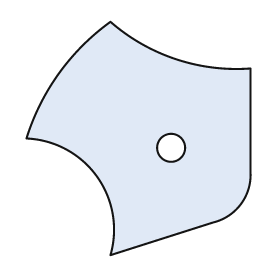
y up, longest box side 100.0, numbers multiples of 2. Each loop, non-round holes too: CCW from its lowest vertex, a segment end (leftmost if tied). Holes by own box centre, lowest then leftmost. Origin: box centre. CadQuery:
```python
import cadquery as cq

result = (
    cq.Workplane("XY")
    .moveTo(-12.0, -50.0)
    .lineTo(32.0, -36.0)
    .threePointArc((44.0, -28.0), (48.0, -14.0))
    .lineTo(48.0, 30.0)
    .threePointArc((16.0, 34.0), (-12.0, 50.0))
    .threePointArc((-34.0, 28.0), (-48.0, 0.0))
    .threePointArc((-18.0, -16.0), (-12.0, -50.0))
    .close()
    .moveTo(14.0, -4.0)
    .circle(6.0)
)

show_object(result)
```